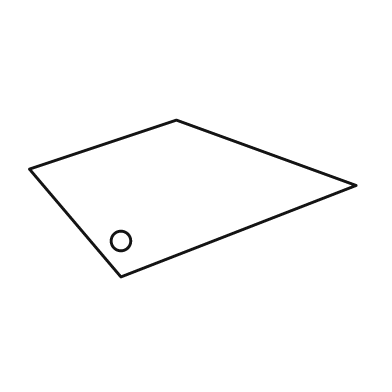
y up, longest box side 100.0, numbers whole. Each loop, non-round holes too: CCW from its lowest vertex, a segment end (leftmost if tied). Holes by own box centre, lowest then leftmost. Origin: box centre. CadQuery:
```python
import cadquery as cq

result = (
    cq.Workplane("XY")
    .moveTo(-22.0, -24.0)
    .lineTo(50.0, 4.0)
    .lineTo(-5.0, 24.0)
    .lineTo(-50.0, 9.0)
    .close()
    .moveTo(-22.0, -13.0)
    .circle(3.0)
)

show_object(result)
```